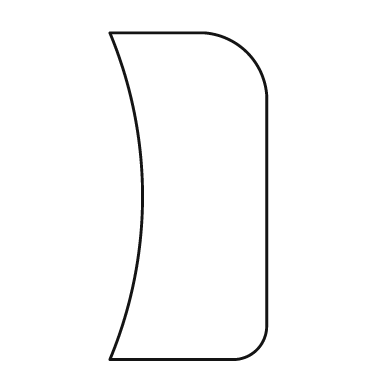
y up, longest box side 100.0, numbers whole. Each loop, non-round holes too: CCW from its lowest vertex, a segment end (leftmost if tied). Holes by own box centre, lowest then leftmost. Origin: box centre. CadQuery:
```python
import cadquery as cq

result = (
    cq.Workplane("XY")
    .moveTo(-24.0, -50.0)
    .lineTo(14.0, -50.0)
    .threePointArc((21.0, -47.0), (24.0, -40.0))
    .lineTo(24.0, 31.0)
    .threePointArc((18.0, 44.0), (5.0, 50.0))
    .lineTo(-24.0, 50.0)
    .threePointArc((-14.0, 0.0), (-24.0, -50.0))
    .close()
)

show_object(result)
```